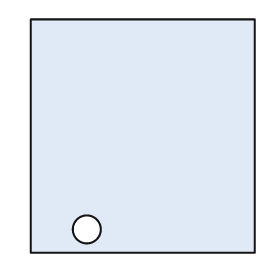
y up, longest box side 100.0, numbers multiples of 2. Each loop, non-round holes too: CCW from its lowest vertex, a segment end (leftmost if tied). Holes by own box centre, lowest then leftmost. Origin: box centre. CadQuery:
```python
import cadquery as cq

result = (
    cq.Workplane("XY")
    .moveTo(-48.0, -50.0)
    .lineTo(48.0, -50.0)
    .lineTo(48.0, 50.0)
    .lineTo(-48.0, 50.0)
    .close()
    .moveTo(-24.0, -40.0)
    .circle(6.0)
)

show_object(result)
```